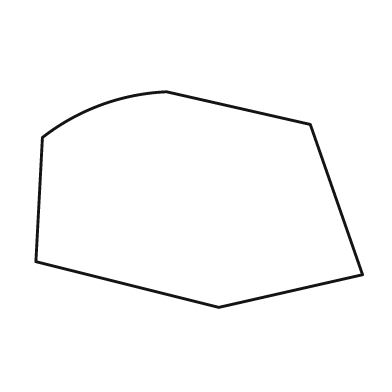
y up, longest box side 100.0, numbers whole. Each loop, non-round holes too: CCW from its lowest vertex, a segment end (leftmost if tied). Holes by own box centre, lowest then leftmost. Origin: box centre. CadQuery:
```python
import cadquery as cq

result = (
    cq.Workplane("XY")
    .moveTo(6.0, -33.0)
    .lineTo(50.0, -23.0)
    .lineTo(34.0, 23.0)
    .lineTo(-10.0, 33.0)
    .threePointArc((-30.0, 29.0), (-48.0, 19.0))
    .lineTo(-50.0, -19.0)
    .close()
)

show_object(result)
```